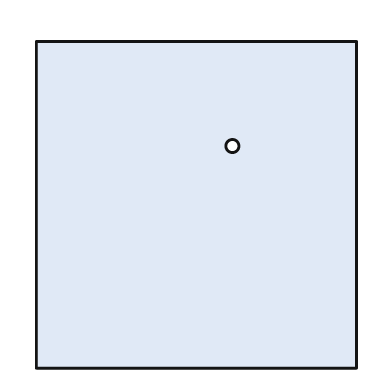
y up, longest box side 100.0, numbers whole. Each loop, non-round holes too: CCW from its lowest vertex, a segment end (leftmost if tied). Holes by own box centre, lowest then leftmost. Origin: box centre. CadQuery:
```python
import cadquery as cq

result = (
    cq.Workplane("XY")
    .moveTo(-49.0, -50.0)
    .lineTo(49.0, -50.0)
    .lineTo(49.0, 50.0)
    .lineTo(-49.0, 50.0)
    .close()
    .moveTo(11.0, 18.0)
    .circle(2.0)
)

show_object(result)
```